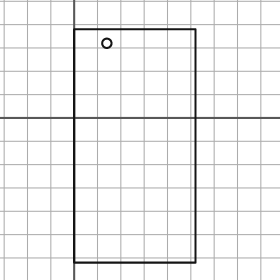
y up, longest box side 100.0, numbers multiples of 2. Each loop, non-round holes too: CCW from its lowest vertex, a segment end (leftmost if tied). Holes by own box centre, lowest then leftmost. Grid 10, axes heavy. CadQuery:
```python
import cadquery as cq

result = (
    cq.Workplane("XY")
    .moveTo(0.0, -62.0)
    .lineTo(52.0, -62.0)
    .lineTo(52.0, 38.0)
    .lineTo(0.0, 38.0)
    .close()
    .moveTo(14.0, 32.0)
    .circle(2.0)
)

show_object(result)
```